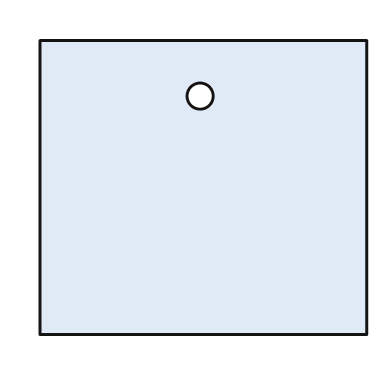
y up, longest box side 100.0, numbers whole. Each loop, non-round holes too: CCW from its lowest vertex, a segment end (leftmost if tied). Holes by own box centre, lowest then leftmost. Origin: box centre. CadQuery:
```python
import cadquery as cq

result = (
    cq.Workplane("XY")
    .moveTo(-50.0, -45.0)
    .lineTo(50.0, -45.0)
    .lineTo(50.0, 45.0)
    .lineTo(-50.0, 45.0)
    .close()
    .moveTo(-1.0, 28.0)
    .circle(4.0)
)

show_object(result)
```